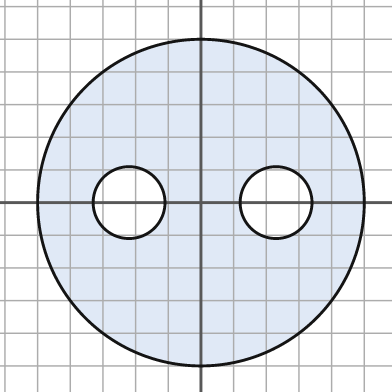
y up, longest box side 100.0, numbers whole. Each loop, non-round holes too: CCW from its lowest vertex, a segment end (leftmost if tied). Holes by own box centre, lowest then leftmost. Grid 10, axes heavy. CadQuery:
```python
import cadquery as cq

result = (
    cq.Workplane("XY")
    .moveTo(0.0, 0.0)
    .circle(50.0)
    .moveTo(-22.0, 0.0)
    .circle(11.0)
    .moveTo(23.0, 0.0)
    .circle(11.0)
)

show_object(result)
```